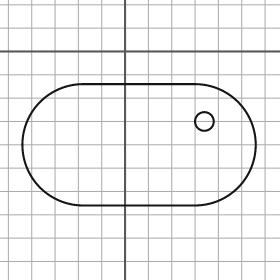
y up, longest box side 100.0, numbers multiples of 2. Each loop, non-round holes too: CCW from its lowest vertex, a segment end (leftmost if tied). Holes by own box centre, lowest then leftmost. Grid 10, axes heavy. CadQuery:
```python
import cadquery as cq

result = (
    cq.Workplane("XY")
    .moveTo(-18.0, -66.0)
    .lineTo(30.0, -66.0)
    .threePointArc((56.0, -40.0), (30.0, -14.0))
    .lineTo(-18.0, -14.0)
    .threePointArc((-44.0, -40.0), (-18.0, -66.0))
    .close()
    .moveTo(34.0, -30.0)
    .circle(4.0)
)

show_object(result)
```